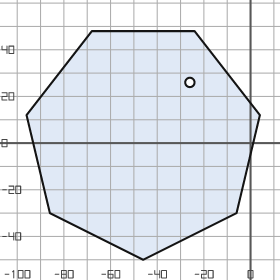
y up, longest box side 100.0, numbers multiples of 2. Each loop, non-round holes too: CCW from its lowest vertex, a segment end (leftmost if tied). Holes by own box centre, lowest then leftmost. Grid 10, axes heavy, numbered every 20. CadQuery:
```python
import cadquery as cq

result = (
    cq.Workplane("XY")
    .moveTo(-46.0, -50.0)
    .lineTo(-6.0, -30.0)
    .lineTo(4.0, 12.0)
    .lineTo(-24.0, 48.0)
    .lineTo(-68.0, 48.0)
    .lineTo(-96.0, 12.0)
    .lineTo(-86.0, -30.0)
    .close()
    .moveTo(-26.0, 26.0)
    .circle(2.0)
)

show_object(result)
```